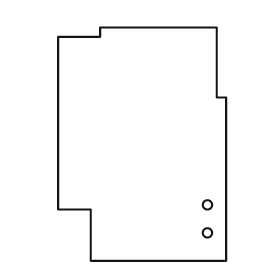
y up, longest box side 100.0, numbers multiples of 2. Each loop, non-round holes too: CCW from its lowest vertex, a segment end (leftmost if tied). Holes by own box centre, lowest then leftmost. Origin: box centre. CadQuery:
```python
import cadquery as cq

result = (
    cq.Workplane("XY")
    .moveTo(-22.0, -50.0)
    .lineTo(36.0, -50.0)
    .lineTo(36.0, 20.0)
    .lineTo(32.0, 20.0)
    .lineTo(32.0, 50.0)
    .lineTo(-18.0, 50.0)
    .lineTo(-18.0, 46.0)
    .lineTo(-36.0, 46.0)
    .lineTo(-36.0, -28.0)
    .lineTo(-22.0, -28.0)
    .close()
    .moveTo(28.0, -38.0)
    .circle(2.0)
    .moveTo(28.0, -26.0)
    .circle(2.0)
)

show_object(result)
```